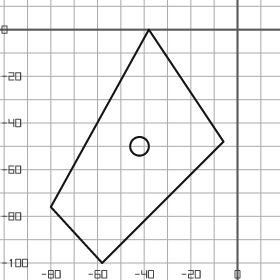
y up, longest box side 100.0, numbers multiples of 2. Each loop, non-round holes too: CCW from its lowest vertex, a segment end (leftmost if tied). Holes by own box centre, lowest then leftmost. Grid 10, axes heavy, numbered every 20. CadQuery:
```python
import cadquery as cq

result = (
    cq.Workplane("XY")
    .moveTo(-58.0, -100.0)
    .lineTo(-6.0, -48.0)
    .lineTo(-38.0, 0.0)
    .lineTo(-80.0, -76.0)
    .close()
    .moveTo(-42.0, -50.0)
    .circle(4.0)
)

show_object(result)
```